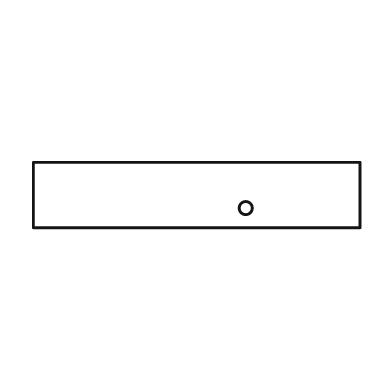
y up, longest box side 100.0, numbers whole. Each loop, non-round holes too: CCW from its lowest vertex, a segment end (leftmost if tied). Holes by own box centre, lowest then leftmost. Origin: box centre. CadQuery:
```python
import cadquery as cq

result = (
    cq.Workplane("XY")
    .moveTo(-50.0, -10.0)
    .lineTo(50.0, -10.0)
    .lineTo(50.0, 10.0)
    .lineTo(-50.0, 10.0)
    .close()
    .moveTo(15.0, -4.0)
    .circle(2.0)
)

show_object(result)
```